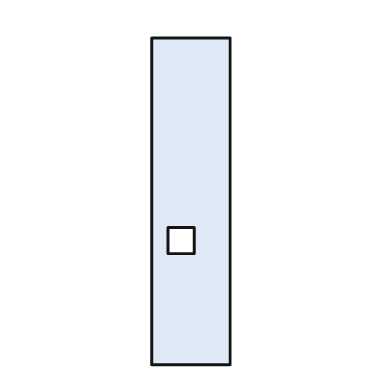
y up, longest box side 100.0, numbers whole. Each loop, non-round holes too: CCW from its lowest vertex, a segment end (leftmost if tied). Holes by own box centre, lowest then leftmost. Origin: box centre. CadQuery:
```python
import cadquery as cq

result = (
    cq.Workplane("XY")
    .moveTo(-12.0, -50.0)
    .lineTo(12.0, -50.0)
    .lineTo(12.0, 50.0)
    .lineTo(-12.0, 50.0)
    .close()
    .moveTo(-7.0, -16.0)
    .lineTo(1.0, -16.0)
    .lineTo(1.0, -8.0)
    .lineTo(-7.0, -8.0)
    .close()
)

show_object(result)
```